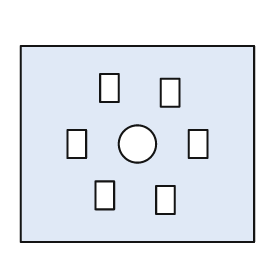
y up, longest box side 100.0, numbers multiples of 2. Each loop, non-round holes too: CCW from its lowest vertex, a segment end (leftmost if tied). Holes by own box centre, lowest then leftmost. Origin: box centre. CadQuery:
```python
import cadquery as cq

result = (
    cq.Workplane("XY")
    .moveTo(-50.0, -42.0)
    .lineTo(50.0, -42.0)
    .lineTo(50.0, 42.0)
    .lineTo(-50.0, 42.0)
    .close()
    .moveTo(8.0, -30.0)
    .lineTo(16.0, -30.0)
    .lineTo(16.0, -18.0)
    .lineTo(8.0, -18.0)
    .close()
    .moveTo(-18.0, -28.0)
    .lineTo(-10.0, -28.0)
    .lineTo(-10.0, -16.0)
    .lineTo(-18.0, -16.0)
    .close()
    .moveTo(-30.0, -6.0)
    .lineTo(-22.0, -6.0)
    .lineTo(-22.0, 6.0)
    .lineTo(-30.0, 6.0)
    .close()
    .moveTo(0.0, 0.0)
    .circle(8.0)
    .moveTo(22.0, -6.0)
    .lineTo(30.0, -6.0)
    .lineTo(30.0, 6.0)
    .lineTo(22.0, 6.0)
    .close()
    .moveTo(10.0, 16.0)
    .lineTo(18.0, 16.0)
    .lineTo(18.0, 28.0)
    .lineTo(10.0, 28.0)
    .close()
    .moveTo(-16.0, 18.0)
    .lineTo(-8.0, 18.0)
    .lineTo(-8.0, 30.0)
    .lineTo(-16.0, 30.0)
    .close()
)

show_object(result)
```